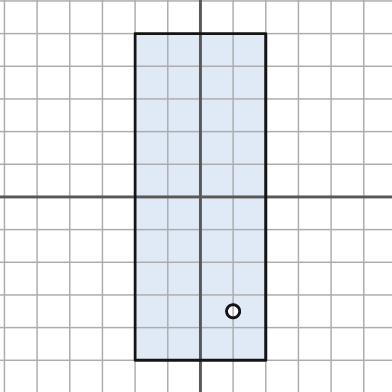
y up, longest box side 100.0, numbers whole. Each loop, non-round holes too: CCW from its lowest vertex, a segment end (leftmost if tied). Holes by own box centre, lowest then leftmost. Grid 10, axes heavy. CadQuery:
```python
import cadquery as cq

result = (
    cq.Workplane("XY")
    .moveTo(-20.0, -50.0)
    .lineTo(20.0, -50.0)
    .lineTo(20.0, 50.0)
    .lineTo(-20.0, 50.0)
    .close()
    .moveTo(10.0, -35.0)
    .circle(2.0)
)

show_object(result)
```